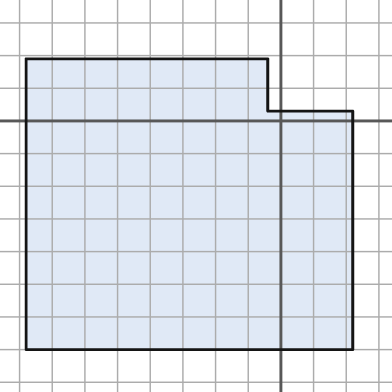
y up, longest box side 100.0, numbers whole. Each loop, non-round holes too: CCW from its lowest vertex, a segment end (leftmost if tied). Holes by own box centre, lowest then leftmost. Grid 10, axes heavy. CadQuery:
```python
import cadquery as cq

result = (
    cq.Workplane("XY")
    .moveTo(-78.0, -70.0)
    .lineTo(22.0, -70.0)
    .lineTo(22.0, 3.0)
    .lineTo(-4.0, 3.0)
    .lineTo(-4.0, 19.0)
    .lineTo(-78.0, 19.0)
    .close()
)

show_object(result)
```